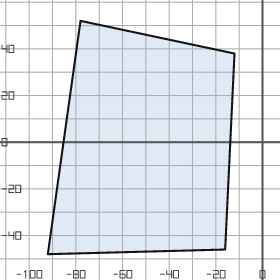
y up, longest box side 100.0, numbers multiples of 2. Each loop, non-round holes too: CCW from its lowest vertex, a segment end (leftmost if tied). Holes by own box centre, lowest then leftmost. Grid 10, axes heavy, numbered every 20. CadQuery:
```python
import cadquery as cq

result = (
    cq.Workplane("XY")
    .moveTo(-92.0, -48.0)
    .lineTo(-16.0, -46.0)
    .lineTo(-12.0, 38.0)
    .lineTo(-78.0, 52.0)
    .close()
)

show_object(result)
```